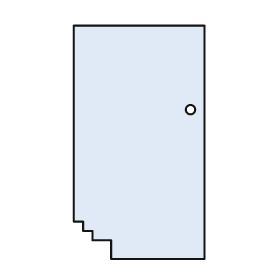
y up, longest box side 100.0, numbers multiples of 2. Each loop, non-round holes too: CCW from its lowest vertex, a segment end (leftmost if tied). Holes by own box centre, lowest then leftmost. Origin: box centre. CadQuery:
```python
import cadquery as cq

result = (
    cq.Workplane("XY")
    .moveTo(-12.0, -50.0)
    .lineTo(28.0, -50.0)
    .lineTo(28.0, 50.0)
    .lineTo(-28.0, 50.0)
    .lineTo(-28.0, -34.0)
    .lineTo(-24.0, -34.0)
    .lineTo(-24.0, -38.0)
    .lineTo(-20.0, -38.0)
    .lineTo(-20.0, -42.0)
    .lineTo(-12.0, -42.0)
    .close()
    .moveTo(22.0, 14.0)
    .circle(2.0)
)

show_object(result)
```